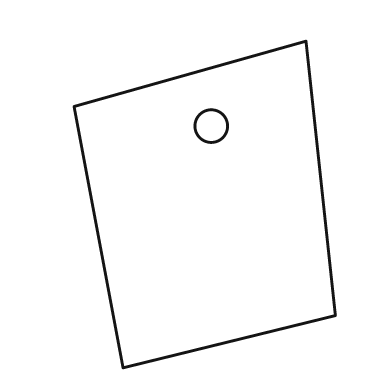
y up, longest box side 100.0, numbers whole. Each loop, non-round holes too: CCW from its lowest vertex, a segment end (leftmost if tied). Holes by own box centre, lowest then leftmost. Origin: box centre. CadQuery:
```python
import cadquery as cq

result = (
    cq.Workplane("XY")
    .moveTo(-25.0, -50.0)
    .lineTo(40.0, -34.0)
    .lineTo(31.0, 50.0)
    .lineTo(-40.0, 30.0)
    .close()
    .moveTo(2.0, 24.0)
    .circle(5.0)
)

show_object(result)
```